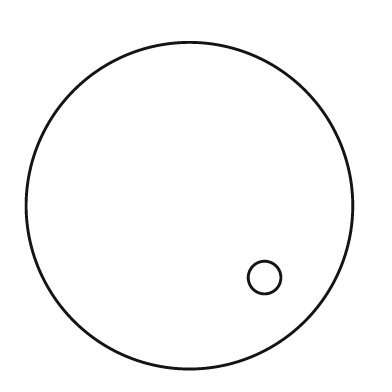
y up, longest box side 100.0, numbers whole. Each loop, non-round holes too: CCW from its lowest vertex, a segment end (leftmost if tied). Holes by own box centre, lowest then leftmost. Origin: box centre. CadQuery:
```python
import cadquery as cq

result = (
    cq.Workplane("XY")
    .moveTo(0.0, 0.0)
    .circle(50.0)
    .moveTo(23.0, -22.0)
    .circle(5.0)
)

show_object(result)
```